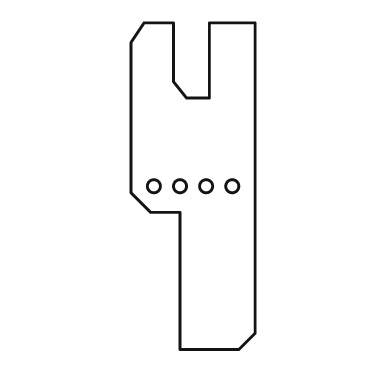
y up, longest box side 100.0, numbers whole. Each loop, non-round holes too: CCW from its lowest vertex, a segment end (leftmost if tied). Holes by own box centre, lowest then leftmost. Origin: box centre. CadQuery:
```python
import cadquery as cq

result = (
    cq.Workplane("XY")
    .moveTo(-4.0, -50.0)
    .lineTo(14.0, -50.0)
    .lineTo(19.0, -45.0)
    .lineTo(19.0, 50.0)
    .lineTo(5.0, 50.0)
    .lineTo(5.0, 27.0)
    .lineTo(-2.0, 27.0)
    .lineTo(-6.0, 32.0)
    .lineTo(-6.0, 50.0)
    .lineTo(-15.0, 50.0)
    .lineTo(-19.0, 44.0)
    .lineTo(-19.0, -2.0)
    .lineTo(-13.0, -8.0)
    .lineTo(-4.0, -8.0)
    .close()
    .moveTo(-12.0, 0.0)
    .circle(2.0)
    .moveTo(-4.0, 0.0)
    .circle(2.0)
    .moveTo(4.0, 0.0)
    .circle(2.0)
    .moveTo(12.0, 0.0)
    .circle(2.0)
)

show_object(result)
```